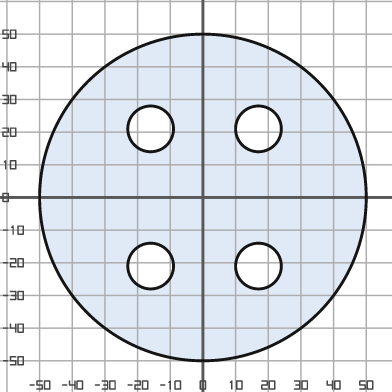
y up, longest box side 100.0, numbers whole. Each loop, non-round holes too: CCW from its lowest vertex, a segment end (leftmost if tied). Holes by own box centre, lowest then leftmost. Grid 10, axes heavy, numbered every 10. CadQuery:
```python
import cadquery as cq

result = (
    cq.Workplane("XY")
    .moveTo(0.0, 0.0)
    .circle(50.0)
    .moveTo(-16.0, -21.0)
    .circle(7.0)
    .moveTo(17.0, -21.0)
    .circle(7.0)
    .moveTo(-16.0, 21.0)
    .circle(7.0)
    .moveTo(17.0, 21.0)
    .circle(7.0)
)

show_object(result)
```